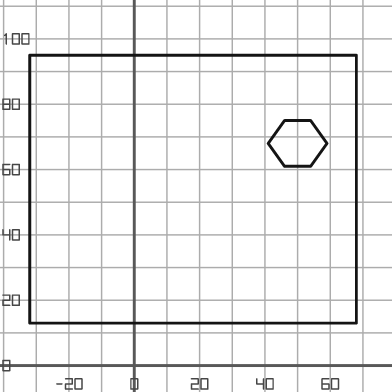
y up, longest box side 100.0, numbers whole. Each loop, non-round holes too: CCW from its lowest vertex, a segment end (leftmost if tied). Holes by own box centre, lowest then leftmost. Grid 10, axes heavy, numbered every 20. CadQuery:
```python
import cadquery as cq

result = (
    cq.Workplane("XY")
    .moveTo(-32.0, 13.0)
    .lineTo(68.0, 13.0)
    .lineTo(68.0, 95.0)
    .lineTo(-32.0, 95.0)
    .close()
    .moveTo(46.0, 61.0)
    .lineTo(54.0, 61.0)
    .lineTo(59.0, 68.0)
    .lineTo(54.0, 75.0)
    .lineTo(46.0, 75.0)
    .lineTo(41.0, 68.0)
    .close()
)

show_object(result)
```